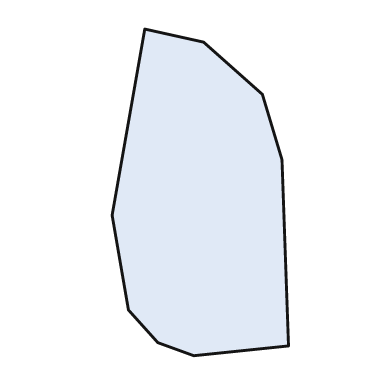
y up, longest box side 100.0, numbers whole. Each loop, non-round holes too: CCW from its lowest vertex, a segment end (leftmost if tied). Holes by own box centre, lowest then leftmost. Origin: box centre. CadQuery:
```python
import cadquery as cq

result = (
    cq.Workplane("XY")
    .moveTo(-2.0, -50.0)
    .lineTo(27.0, -47.0)
    .lineTo(25.0, 10.0)
    .lineTo(19.0, 30.0)
    .lineTo(1.0, 46.0)
    .lineTo(-17.0, 50.0)
    .lineTo(-27.0, -7.0)
    .lineTo(-22.0, -36.0)
    .lineTo(-13.0, -46.0)
    .close()
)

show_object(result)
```